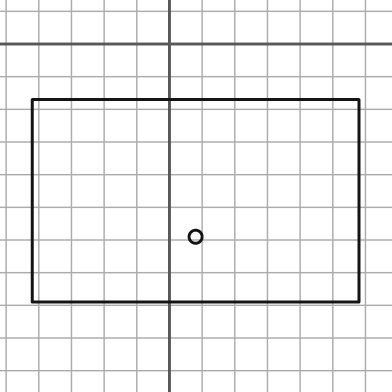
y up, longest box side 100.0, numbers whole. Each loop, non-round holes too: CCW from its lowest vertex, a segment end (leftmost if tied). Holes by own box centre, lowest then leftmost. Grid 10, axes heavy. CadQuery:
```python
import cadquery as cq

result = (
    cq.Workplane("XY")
    .moveTo(-42.0, -79.0)
    .lineTo(58.0, -79.0)
    .lineTo(58.0, -17.0)
    .lineTo(-42.0, -17.0)
    .close()
    .moveTo(8.0, -59.0)
    .circle(2.0)
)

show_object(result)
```